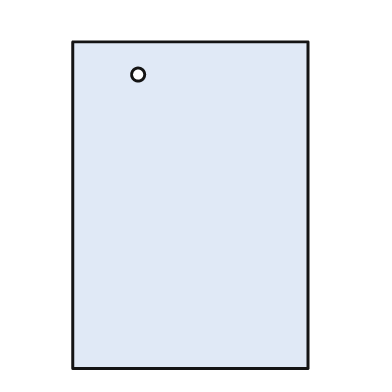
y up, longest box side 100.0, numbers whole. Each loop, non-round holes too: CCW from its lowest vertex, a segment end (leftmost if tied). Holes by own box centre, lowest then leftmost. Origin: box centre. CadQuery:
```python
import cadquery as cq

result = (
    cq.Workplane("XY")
    .moveTo(-36.0, -50.0)
    .lineTo(36.0, -50.0)
    .lineTo(36.0, 50.0)
    .lineTo(-36.0, 50.0)
    .close()
    .moveTo(-16.0, 40.0)
    .circle(2.0)
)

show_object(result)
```